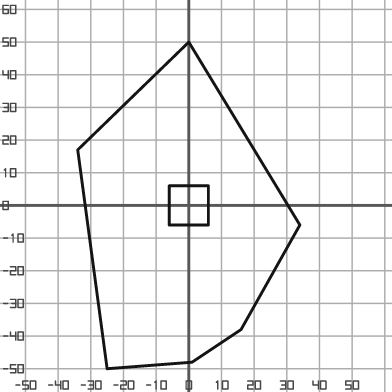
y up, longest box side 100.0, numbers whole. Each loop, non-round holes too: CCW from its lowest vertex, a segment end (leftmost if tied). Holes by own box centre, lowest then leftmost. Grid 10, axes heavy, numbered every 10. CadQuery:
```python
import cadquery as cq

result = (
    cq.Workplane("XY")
    .moveTo(-25.0, -50.0)
    .lineTo(1.0, -48.0)
    .lineTo(16.0, -38.0)
    .lineTo(34.0, -6.0)
    .lineTo(0.0, 50.0)
    .lineTo(-34.0, 17.0)
    .close()
    .moveTo(-6.0, -6.0)
    .lineTo(6.0, -6.0)
    .lineTo(6.0, 6.0)
    .lineTo(-6.0, 6.0)
    .close()
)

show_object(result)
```